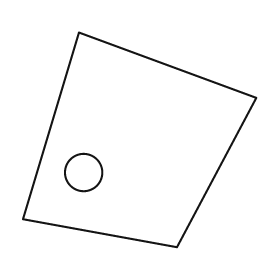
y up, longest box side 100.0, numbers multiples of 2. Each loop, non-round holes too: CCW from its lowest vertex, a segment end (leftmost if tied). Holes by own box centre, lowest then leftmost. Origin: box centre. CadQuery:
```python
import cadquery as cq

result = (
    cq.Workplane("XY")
    .moveTo(16.0, -46.0)
    .lineTo(50.0, 18.0)
    .lineTo(-26.0, 46.0)
    .lineTo(-50.0, -34.0)
    .close()
    .moveTo(-24.0, -14.0)
    .circle(8.0)
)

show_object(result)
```